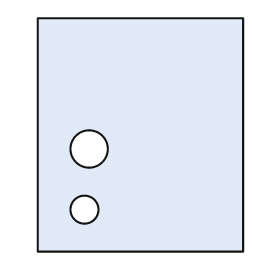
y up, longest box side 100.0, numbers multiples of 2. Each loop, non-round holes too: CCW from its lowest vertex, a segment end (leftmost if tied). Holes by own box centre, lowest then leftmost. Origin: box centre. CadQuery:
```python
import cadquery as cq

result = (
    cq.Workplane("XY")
    .moveTo(-44.0, -50.0)
    .lineTo(44.0, -50.0)
    .lineTo(44.0, 50.0)
    .lineTo(-44.0, 50.0)
    .close()
    .moveTo(-24.0, -32.0)
    .circle(6.0)
    .moveTo(-22.0, -6.0)
    .circle(8.0)
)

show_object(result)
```